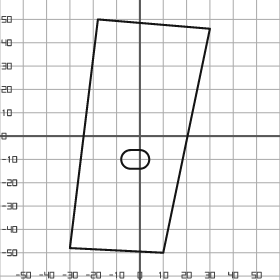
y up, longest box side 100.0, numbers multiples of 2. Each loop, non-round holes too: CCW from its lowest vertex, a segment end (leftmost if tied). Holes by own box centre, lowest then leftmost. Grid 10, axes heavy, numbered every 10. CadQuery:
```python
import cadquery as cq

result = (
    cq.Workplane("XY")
    .moveTo(10.0, -50.0)
    .lineTo(30.0, 46.0)
    .lineTo(-18.0, 50.0)
    .lineTo(-30.0, -48.0)
    .close()
    .moveTo(-4.0, -14.0)
    .lineTo(0.0, -14.0)
    .threePointArc((4.0, -10.0), (0.0, -6.0))
    .lineTo(-4.0, -6.0)
    .threePointArc((-8.0, -10.0), (-4.0, -14.0))
    .close()
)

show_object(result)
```